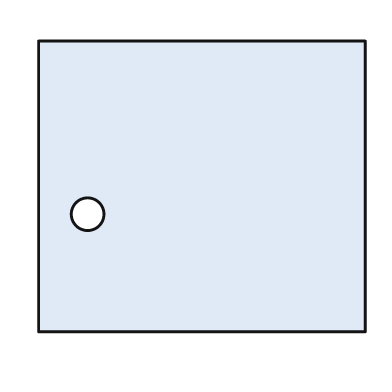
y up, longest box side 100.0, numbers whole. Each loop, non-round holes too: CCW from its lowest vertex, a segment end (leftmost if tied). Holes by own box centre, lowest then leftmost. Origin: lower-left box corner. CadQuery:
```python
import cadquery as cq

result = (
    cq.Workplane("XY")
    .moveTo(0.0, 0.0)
    .lineTo(100.0, 0.0)
    .lineTo(100.0, 89.0)
    .lineTo(0.0, 89.0)
    .close()
    .moveTo(15.0, 36.0)
    .circle(5.0)
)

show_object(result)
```